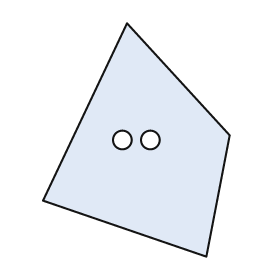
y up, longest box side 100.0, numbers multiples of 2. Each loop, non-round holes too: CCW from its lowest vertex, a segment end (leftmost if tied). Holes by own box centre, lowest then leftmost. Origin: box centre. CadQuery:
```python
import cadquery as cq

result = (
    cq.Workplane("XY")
    .moveTo(30.0, -50.0)
    .lineTo(40.0, 2.0)
    .lineTo(-4.0, 50.0)
    .lineTo(-40.0, -26.0)
    .close()
    .moveTo(-6.0, 0.0)
    .circle(4.0)
    .moveTo(6.0, 0.0)
    .circle(4.0)
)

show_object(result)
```